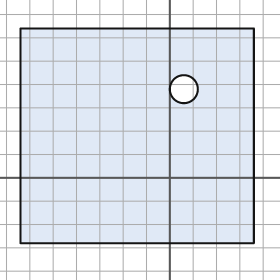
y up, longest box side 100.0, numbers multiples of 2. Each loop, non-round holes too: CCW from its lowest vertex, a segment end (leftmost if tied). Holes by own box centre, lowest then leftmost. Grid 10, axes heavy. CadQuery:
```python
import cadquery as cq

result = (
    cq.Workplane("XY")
    .moveTo(-64.0, -28.0)
    .lineTo(36.0, -28.0)
    .lineTo(36.0, 64.0)
    .lineTo(-64.0, 64.0)
    .close()
    .moveTo(6.0, 38.0)
    .circle(6.0)
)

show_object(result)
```